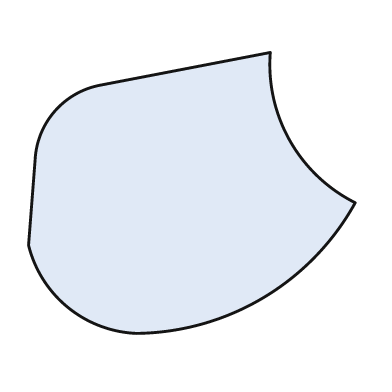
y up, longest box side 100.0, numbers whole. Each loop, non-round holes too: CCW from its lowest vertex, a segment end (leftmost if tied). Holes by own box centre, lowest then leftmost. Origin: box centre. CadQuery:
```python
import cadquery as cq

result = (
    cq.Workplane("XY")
    .moveTo(-17.0, -43.0)
    .threePointArc((22.0, -32.0), (50.0, -3.0))
    .threePointArc((30.0, 16.0), (24.0, 43.0))
    .lineTo(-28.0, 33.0)
    .threePointArc((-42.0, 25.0), (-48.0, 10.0))
    .lineTo(-50.0, -16.0)
    .threePointArc((-38.0, -35.0), (-17.0, -43.0))
    .close()
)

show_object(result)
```